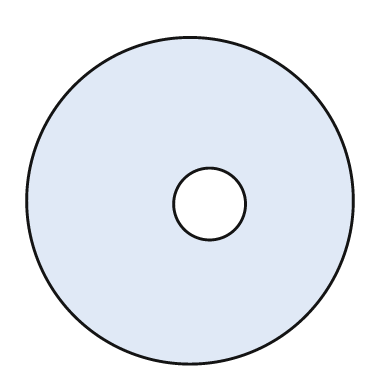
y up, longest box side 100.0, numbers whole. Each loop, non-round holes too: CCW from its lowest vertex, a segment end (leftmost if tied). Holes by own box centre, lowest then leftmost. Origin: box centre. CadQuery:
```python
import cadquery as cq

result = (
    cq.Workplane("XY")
    .moveTo(0.0, 0.0)
    .circle(50.0)
    .moveTo(6.0, -1.0)
    .circle(11.0)
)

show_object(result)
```